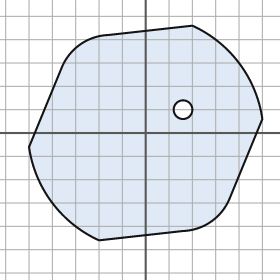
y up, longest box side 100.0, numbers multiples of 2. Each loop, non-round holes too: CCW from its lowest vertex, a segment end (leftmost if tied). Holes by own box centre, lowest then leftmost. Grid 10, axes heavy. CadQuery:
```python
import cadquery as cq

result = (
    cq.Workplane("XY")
    .moveTo(-20.0, -46.0)
    .lineTo(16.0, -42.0)
    .threePointArc((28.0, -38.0), (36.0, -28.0))
    .lineTo(50.0, 6.0)
    .threePointArc((40.0, 30.0), (20.0, 46.0))
    .lineTo(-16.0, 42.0)
    .threePointArc((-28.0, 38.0), (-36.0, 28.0))
    .lineTo(-50.0, -6.0)
    .threePointArc((-40.0, -30.0), (-20.0, -46.0))
    .close()
    .moveTo(16.0, 10.0)
    .circle(4.0)
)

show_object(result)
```